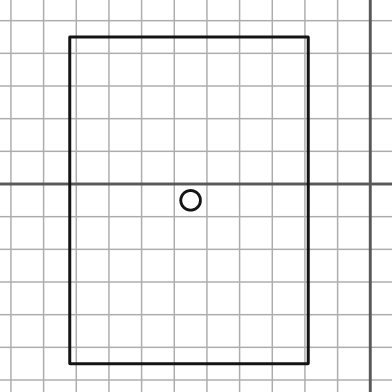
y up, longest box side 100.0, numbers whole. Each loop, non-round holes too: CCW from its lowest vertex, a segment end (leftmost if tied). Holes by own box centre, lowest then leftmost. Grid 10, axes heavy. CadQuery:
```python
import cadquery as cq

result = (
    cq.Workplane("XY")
    .moveTo(-92.0, -55.0)
    .lineTo(-19.0, -55.0)
    .lineTo(-19.0, 45.0)
    .lineTo(-92.0, 45.0)
    .close()
    .moveTo(-55.0, -5.0)
    .circle(3.0)
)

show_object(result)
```